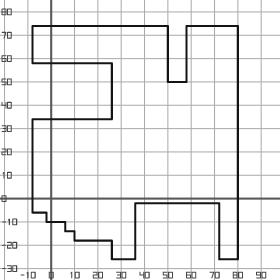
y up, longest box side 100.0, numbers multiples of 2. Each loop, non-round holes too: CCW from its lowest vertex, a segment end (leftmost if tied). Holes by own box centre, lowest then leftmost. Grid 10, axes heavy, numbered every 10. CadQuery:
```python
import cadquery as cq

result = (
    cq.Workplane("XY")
    .moveTo(26.0, -26.0)
    .lineTo(36.0, -26.0)
    .lineTo(36.0, -2.0)
    .lineTo(72.0, -2.0)
    .lineTo(72.0, -26.0)
    .lineTo(80.0, -26.0)
    .lineTo(80.0, 74.0)
    .lineTo(58.0, 74.0)
    .lineTo(58.0, 50.0)
    .lineTo(50.0, 50.0)
    .lineTo(50.0, 74.0)
    .lineTo(-8.0, 74.0)
    .lineTo(-8.0, 58.0)
    .lineTo(26.0, 58.0)
    .lineTo(26.0, 34.0)
    .lineTo(-8.0, 34.0)
    .lineTo(-8.0, -6.0)
    .lineTo(-2.0, -6.0)
    .lineTo(-2.0, -10.0)
    .lineTo(6.0, -10.0)
    .lineTo(6.0, -14.0)
    .lineTo(10.0, -14.0)
    .lineTo(10.0, -18.0)
    .lineTo(26.0, -18.0)
    .close()
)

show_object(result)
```